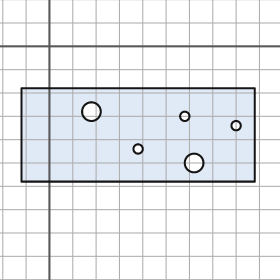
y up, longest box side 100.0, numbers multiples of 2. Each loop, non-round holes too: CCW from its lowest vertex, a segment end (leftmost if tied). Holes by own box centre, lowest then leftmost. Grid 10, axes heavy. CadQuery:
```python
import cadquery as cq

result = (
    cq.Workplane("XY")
    .moveTo(-12.0, -58.0)
    .lineTo(88.0, -58.0)
    .lineTo(88.0, -18.0)
    .lineTo(-12.0, -18.0)
    .close()
    .moveTo(62.0, -50.0)
    .circle(4.0)
    .moveTo(38.0, -44.0)
    .circle(2.0)
    .moveTo(80.0, -34.0)
    .circle(2.0)
    .moveTo(58.0, -30.0)
    .circle(2.0)
    .moveTo(18.0, -28.0)
    .circle(4.0)
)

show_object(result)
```